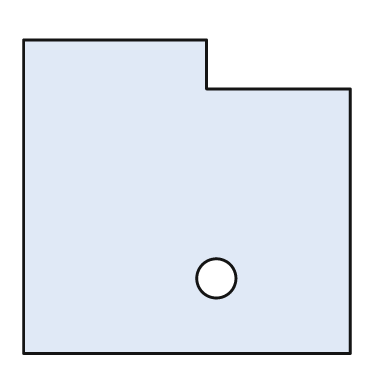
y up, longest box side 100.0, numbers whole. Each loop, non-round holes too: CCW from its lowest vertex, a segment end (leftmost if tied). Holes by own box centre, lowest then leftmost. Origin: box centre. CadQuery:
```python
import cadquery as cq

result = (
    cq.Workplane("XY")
    .moveTo(-50.0, -48.0)
    .lineTo(50.0, -48.0)
    .lineTo(50.0, 33.0)
    .lineTo(6.0, 33.0)
    .lineTo(6.0, 48.0)
    .lineTo(-50.0, 48.0)
    .close()
    .moveTo(9.0, -25.0)
    .circle(6.0)
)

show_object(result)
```